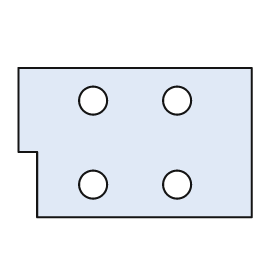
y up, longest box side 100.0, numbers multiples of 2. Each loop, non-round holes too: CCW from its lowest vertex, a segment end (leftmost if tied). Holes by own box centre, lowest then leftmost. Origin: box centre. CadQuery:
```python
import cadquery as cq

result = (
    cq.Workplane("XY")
    .moveTo(-42.0, -32.0)
    .lineTo(50.0, -32.0)
    .lineTo(50.0, 32.0)
    .lineTo(-50.0, 32.0)
    .lineTo(-50.0, -4.0)
    .lineTo(-42.0, -4.0)
    .close()
    .moveTo(-18.0, -18.0)
    .circle(6.0)
    .moveTo(18.0, -18.0)
    .circle(6.0)
    .moveTo(-18.0, 18.0)
    .circle(6.0)
    .moveTo(18.0, 18.0)
    .circle(6.0)
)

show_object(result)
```